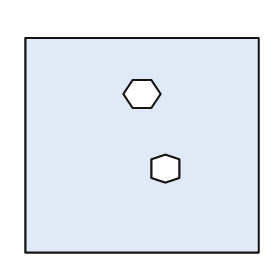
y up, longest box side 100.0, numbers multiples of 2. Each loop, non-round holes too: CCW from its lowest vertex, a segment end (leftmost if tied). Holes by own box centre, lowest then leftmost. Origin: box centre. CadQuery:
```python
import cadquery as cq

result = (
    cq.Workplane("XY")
    .moveTo(-50.0, -46.0)
    .lineTo(50.0, -46.0)
    .lineTo(50.0, 46.0)
    .lineTo(-50.0, 46.0)
    .close()
    .moveTo(10.0, -16.0)
    .lineTo(16.0, -14.0)
    .lineTo(16.0, -6.0)
    .lineTo(10.0, -4.0)
    .lineTo(4.0, -6.0)
    .lineTo(4.0, -14.0)
    .close()
    .moveTo(-4.0, 16.0)
    .lineTo(4.0, 16.0)
    .lineTo(8.0, 22.0)
    .lineTo(4.0, 28.0)
    .lineTo(-4.0, 28.0)
    .lineTo(-8.0, 22.0)
    .close()
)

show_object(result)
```